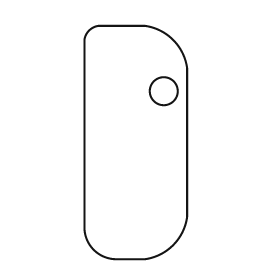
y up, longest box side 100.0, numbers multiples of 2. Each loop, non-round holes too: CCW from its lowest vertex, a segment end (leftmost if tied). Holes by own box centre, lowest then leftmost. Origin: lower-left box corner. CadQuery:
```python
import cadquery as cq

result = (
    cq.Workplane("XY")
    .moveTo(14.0, 0.0)
    .lineTo(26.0, 0.0)
    .threePointArc((38.0, 6.0), (44.0, 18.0))
    .lineTo(44.0, 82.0)
    .threePointArc((38.0, 94.0), (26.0, 100.0))
    .lineTo(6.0, 100.0)
    .threePointArc((2.0, 98.0), (0.0, 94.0))
    .lineTo(0.0, 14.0)
    .threePointArc((4.0, 4.0), (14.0, 0.0))
    .close()
    .moveTo(34.0, 72.0)
    .circle(6.0)
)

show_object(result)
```